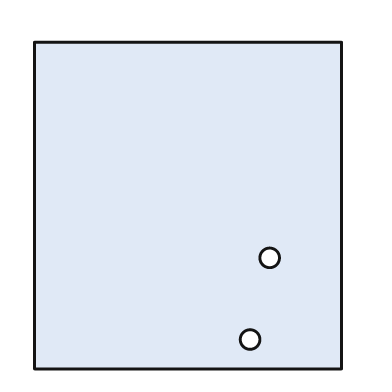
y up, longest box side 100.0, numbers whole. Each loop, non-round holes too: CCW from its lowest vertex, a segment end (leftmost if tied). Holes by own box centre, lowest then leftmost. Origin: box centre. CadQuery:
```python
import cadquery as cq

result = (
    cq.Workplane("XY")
    .moveTo(-47.0, -50.0)
    .lineTo(47.0, -50.0)
    .lineTo(47.0, 50.0)
    .lineTo(-47.0, 50.0)
    .close()
    .moveTo(19.0, -41.0)
    .circle(3.0)
    .moveTo(25.0, -16.0)
    .circle(3.0)
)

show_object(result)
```